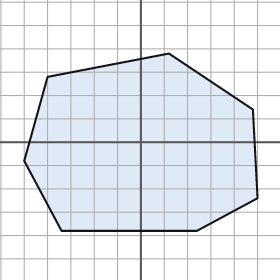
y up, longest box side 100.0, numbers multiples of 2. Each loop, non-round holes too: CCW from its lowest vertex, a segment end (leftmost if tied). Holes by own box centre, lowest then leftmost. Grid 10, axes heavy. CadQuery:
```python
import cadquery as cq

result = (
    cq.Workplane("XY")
    .moveTo(-34.0, -38.0)
    .lineTo(24.0, -38.0)
    .lineTo(50.0, -24.0)
    .lineTo(48.0, 14.0)
    .lineTo(12.0, 38.0)
    .lineTo(-40.0, 28.0)
    .lineTo(-50.0, -8.0)
    .close()
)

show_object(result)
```